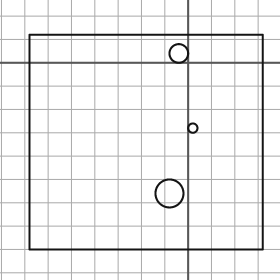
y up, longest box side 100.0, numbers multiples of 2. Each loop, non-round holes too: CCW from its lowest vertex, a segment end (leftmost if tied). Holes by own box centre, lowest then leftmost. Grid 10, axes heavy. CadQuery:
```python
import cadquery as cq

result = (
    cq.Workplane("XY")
    .moveTo(-68.0, -80.0)
    .lineTo(32.0, -80.0)
    .lineTo(32.0, 12.0)
    .lineTo(-68.0, 12.0)
    .close()
    .moveTo(-8.0, -56.0)
    .circle(6.0)
    .moveTo(2.0, -28.0)
    .circle(2.0)
    .moveTo(-4.0, 4.0)
    .circle(4.0)
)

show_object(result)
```